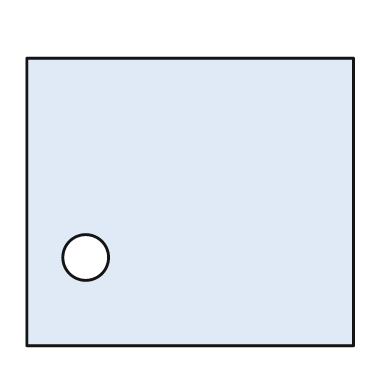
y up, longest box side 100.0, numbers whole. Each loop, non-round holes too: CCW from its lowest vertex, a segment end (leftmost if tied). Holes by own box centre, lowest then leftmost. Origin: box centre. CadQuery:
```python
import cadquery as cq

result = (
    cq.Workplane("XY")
    .moveTo(-50.0, -44.0)
    .lineTo(50.0, -44.0)
    .lineTo(50.0, 44.0)
    .lineTo(-50.0, 44.0)
    .close()
    .moveTo(-32.0, -17.0)
    .circle(7.0)
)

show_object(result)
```